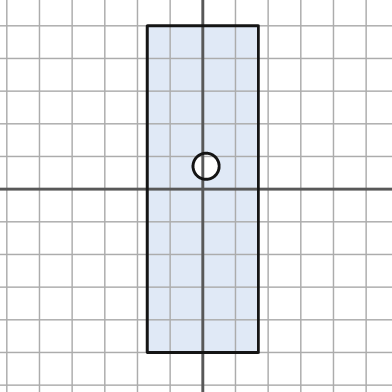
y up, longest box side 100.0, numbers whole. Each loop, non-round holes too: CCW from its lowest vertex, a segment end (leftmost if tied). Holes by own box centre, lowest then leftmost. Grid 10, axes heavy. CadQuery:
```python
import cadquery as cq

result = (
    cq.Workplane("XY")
    .moveTo(-17.0, -50.0)
    .lineTo(17.0, -50.0)
    .lineTo(17.0, 50.0)
    .lineTo(-17.0, 50.0)
    .close()
    .moveTo(1.0, 7.0)
    .circle(4.0)
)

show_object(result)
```